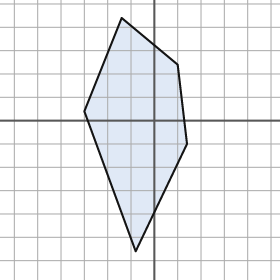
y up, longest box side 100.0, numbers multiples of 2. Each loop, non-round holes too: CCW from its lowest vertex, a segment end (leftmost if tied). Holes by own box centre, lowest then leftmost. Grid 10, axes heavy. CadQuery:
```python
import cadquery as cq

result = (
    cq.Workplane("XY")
    .moveTo(-8.0, -56.0)
    .lineTo(14.0, -10.0)
    .lineTo(10.0, 24.0)
    .lineTo(-14.0, 44.0)
    .lineTo(-30.0, 4.0)
    .close()
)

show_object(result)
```